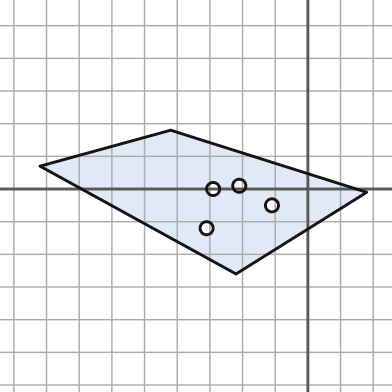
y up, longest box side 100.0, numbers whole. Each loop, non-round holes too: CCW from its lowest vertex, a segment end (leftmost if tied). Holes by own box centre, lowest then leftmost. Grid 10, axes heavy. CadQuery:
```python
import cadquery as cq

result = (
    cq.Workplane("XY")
    .moveTo(-22.0, -26.0)
    .lineTo(18.0, -1.0)
    .lineTo(-42.0, 18.0)
    .lineTo(-82.0, 7.0)
    .close()
    .moveTo(-31.0, -12.0)
    .circle(2.0)
    .moveTo(-11.0, -5.0)
    .circle(2.0)
    .moveTo(-29.0, 0.0)
    .circle(2.0)
    .moveTo(-21.0, 1.0)
    .circle(2.0)
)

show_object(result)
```